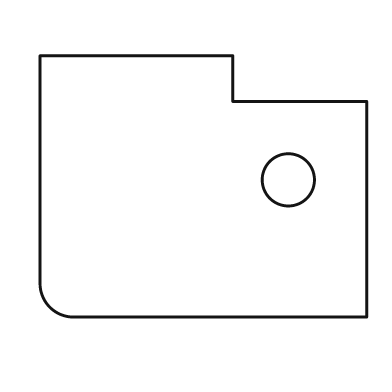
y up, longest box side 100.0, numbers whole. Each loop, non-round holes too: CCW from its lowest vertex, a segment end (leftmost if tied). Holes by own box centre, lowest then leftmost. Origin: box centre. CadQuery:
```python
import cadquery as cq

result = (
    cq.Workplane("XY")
    .moveTo(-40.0, -40.0)
    .lineTo(50.0, -40.0)
    .lineTo(50.0, 26.0)
    .lineTo(9.0, 26.0)
    .lineTo(9.0, 40.0)
    .lineTo(-50.0, 40.0)
    .lineTo(-50.0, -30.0)
    .threePointArc((-47.0, -37.0), (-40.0, -40.0))
    .close()
    .moveTo(26.0, 2.0)
    .circle(8.0)
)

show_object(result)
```